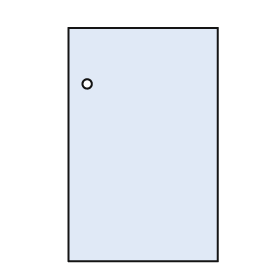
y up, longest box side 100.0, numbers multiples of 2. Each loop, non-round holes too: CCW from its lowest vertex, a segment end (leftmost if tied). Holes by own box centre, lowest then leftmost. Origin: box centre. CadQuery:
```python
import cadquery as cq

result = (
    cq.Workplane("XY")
    .moveTo(-32.0, -50.0)
    .lineTo(32.0, -50.0)
    .lineTo(32.0, 50.0)
    .lineTo(-32.0, 50.0)
    .close()
    .moveTo(-24.0, 26.0)
    .circle(2.0)
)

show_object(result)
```